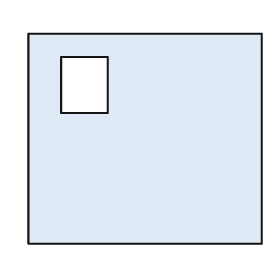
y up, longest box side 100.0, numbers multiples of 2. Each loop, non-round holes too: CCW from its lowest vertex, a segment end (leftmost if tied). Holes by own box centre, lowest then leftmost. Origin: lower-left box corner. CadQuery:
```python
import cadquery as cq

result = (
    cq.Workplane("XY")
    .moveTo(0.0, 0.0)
    .lineTo(100.0, 0.0)
    .lineTo(100.0, 90.0)
    .lineTo(0.0, 90.0)
    .close()
    .moveTo(14.0, 56.0)
    .lineTo(34.0, 56.0)
    .lineTo(34.0, 80.0)
    .lineTo(14.0, 80.0)
    .close()
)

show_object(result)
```